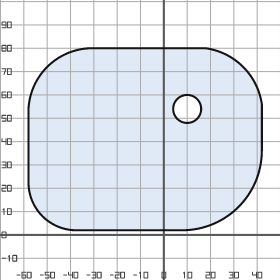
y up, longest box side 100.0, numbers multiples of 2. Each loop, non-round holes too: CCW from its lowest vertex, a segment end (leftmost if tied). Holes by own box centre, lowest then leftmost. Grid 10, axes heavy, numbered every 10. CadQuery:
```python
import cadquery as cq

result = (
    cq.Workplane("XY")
    .moveTo(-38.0, 2.0)
    .lineTo(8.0, 2.0)
    .threePointArc((32.0, 12.0), (42.0, 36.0))
    .lineTo(42.0, 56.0)
    .threePointArc((34.0, 72.0), (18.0, 80.0))
    .lineTo(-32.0, 80.0)
    .threePointArc((-50.0, 72.0), (-58.0, 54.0))
    .lineTo(-58.0, 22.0)
    .threePointArc((-52.0, 8.0), (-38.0, 2.0))
    .close()
    .moveTo(10.0, 54.0)
    .circle(6.0)
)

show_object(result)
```